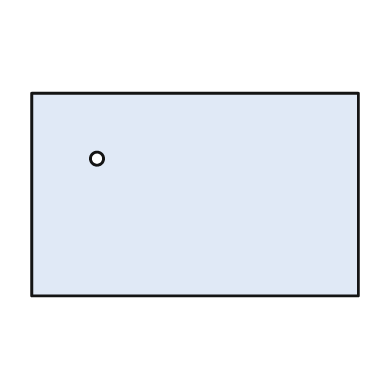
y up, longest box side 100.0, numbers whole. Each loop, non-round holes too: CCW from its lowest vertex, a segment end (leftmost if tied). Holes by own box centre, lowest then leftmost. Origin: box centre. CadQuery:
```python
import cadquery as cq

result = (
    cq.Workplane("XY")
    .moveTo(-50.0, -31.0)
    .lineTo(50.0, -31.0)
    .lineTo(50.0, 31.0)
    .lineTo(-50.0, 31.0)
    .close()
    .moveTo(-30.0, 11.0)
    .circle(2.0)
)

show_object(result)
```